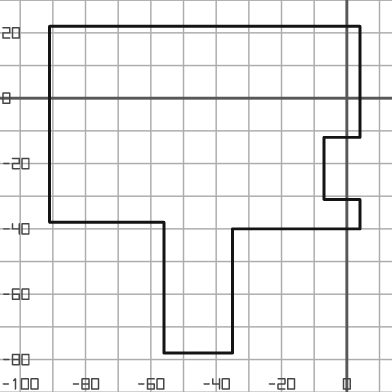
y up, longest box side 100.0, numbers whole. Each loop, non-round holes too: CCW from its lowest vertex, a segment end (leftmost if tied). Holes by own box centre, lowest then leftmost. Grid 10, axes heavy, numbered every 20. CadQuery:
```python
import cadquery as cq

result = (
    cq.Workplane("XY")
    .moveTo(-56.0, -78.0)
    .lineTo(-35.0, -78.0)
    .lineTo(-35.0, -40.0)
    .lineTo(4.0, -40.0)
    .lineTo(4.0, -31.0)
    .lineTo(-7.0, -31.0)
    .lineTo(-7.0, -12.0)
    .lineTo(4.0, -12.0)
    .lineTo(4.0, 22.0)
    .lineTo(-91.0, 22.0)
    .lineTo(-91.0, -38.0)
    .lineTo(-56.0, -38.0)
    .close()
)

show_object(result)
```